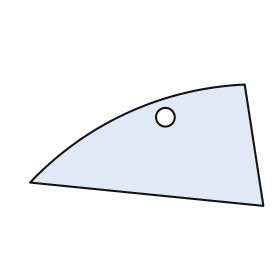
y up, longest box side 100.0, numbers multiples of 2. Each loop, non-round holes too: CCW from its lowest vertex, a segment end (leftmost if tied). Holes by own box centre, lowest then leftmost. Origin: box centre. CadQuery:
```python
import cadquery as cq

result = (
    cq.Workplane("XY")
    .moveTo(50.0, -26.0)
    .lineTo(42.0, 26.0)
    .threePointArc((-8.0, 14.0), (-50.0, -16.0))
    .close()
    .moveTo(8.0, 12.0)
    .circle(4.0)
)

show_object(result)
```